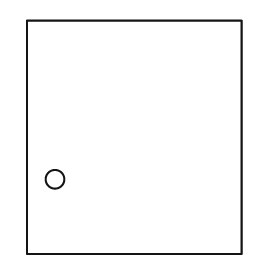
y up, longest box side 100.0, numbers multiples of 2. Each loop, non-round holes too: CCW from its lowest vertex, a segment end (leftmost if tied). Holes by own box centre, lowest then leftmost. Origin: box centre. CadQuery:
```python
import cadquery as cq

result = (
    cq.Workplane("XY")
    .moveTo(-46.0, -50.0)
    .lineTo(46.0, -50.0)
    .lineTo(46.0, 50.0)
    .lineTo(-46.0, 50.0)
    .close()
    .moveTo(-34.0, -18.0)
    .circle(4.0)
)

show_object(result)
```